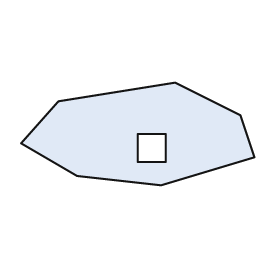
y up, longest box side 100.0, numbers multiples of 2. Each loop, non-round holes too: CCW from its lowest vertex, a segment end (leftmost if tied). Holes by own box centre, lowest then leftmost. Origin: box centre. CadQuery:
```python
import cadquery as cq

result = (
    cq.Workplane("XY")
    .moveTo(10.0, -22.0)
    .lineTo(50.0, -10.0)
    .lineTo(44.0, 8.0)
    .lineTo(16.0, 22.0)
    .lineTo(-34.0, 14.0)
    .lineTo(-50.0, -4.0)
    .lineTo(-26.0, -18.0)
    .close()
    .moveTo(0.0, -12.0)
    .lineTo(12.0, -12.0)
    .lineTo(12.0, 0.0)
    .lineTo(0.0, 0.0)
    .close()
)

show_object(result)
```